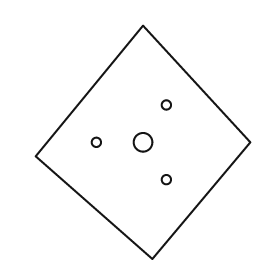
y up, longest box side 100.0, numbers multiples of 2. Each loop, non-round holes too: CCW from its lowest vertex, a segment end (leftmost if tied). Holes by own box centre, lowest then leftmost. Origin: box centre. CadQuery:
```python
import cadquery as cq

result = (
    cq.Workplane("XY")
    .moveTo(4.0, -50.0)
    .lineTo(46.0, 0.0)
    .lineTo(0.0, 50.0)
    .lineTo(-46.0, -6.0)
    .close()
    .moveTo(10.0, -16.0)
    .circle(2.0)
    .moveTo(-20.0, 0.0)
    .circle(2.0)
    .moveTo(0.0, 0.0)
    .circle(4.0)
    .moveTo(10.0, 16.0)
    .circle(2.0)
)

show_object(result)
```